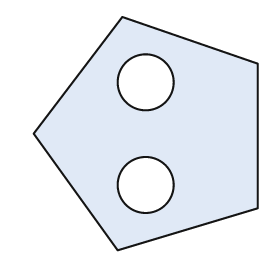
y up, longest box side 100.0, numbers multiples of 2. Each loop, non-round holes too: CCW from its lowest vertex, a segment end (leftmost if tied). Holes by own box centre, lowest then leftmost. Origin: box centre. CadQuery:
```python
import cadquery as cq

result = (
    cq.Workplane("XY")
    .moveTo(-12.0, -50.0)
    .lineTo(48.0, -32.0)
    .lineTo(48.0, 30.0)
    .lineTo(-10.0, 50.0)
    .lineTo(-48.0, 0.0)
    .close()
    .moveTo(0.0, -22.0)
    .circle(12.0)
    .moveTo(0.0, 22.0)
    .circle(12.0)
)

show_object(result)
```